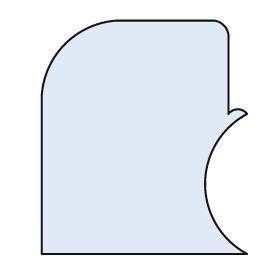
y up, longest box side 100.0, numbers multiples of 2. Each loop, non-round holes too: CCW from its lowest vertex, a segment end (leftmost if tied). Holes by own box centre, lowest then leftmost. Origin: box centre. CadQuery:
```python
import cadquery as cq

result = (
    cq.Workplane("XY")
    .moveTo(-44.0, -50.0)
    .lineTo(44.0, -50.0)
    .threePointArc((26.0, -20.0), (44.0, 10.0))
    .threePointArc((40.0, 12.0), (36.0, 10.0))
    .lineTo(36.0, 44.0)
    .threePointArc((34.0, 48.0), (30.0, 50.0))
    .lineTo(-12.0, 50.0)
    .threePointArc((-34.0, 40.0), (-44.0, 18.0))
    .close()
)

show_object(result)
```